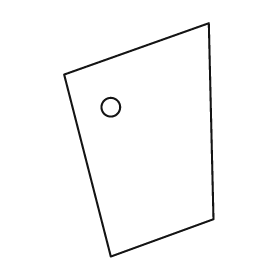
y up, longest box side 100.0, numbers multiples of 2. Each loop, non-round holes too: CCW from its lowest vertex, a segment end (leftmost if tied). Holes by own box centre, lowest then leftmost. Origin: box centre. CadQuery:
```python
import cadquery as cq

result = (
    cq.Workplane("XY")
    .moveTo(-12.0, -50.0)
    .lineTo(32.0, -34.0)
    .lineTo(30.0, 50.0)
    .lineTo(-32.0, 28.0)
    .close()
    .moveTo(-12.0, 14.0)
    .circle(4.0)
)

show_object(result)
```